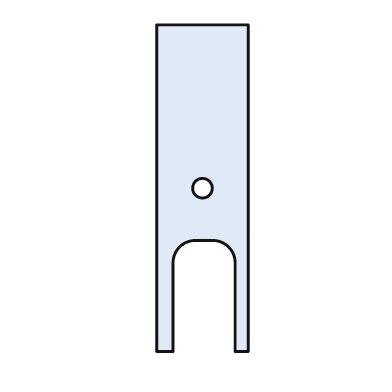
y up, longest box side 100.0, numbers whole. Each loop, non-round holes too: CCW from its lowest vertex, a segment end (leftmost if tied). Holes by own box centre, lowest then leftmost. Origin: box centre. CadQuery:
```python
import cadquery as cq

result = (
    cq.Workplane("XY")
    .moveTo(-14.0, -50.0)
    .lineTo(-9.0, -50.0)
    .lineTo(-9.0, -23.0)
    .threePointArc((-7.0, -18.0), (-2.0, -16.0))
    .lineTo(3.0, -16.0)
    .threePointArc((8.0, -18.0), (10.0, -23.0))
    .lineTo(10.0, -50.0)
    .lineTo(14.0, -50.0)
    .lineTo(14.0, 50.0)
    .lineTo(-14.0, 50.0)
    .close()
    .moveTo(0.0, 0.0)
    .circle(3.0)
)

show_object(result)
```